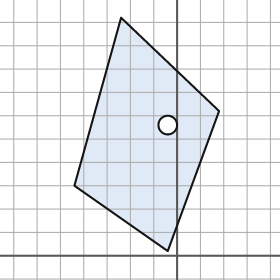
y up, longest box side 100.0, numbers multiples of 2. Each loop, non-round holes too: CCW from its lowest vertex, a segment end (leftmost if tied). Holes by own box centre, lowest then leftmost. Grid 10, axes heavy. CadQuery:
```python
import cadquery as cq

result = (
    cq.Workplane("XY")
    .moveTo(-4.0, 2.0)
    .lineTo(18.0, 62.0)
    .lineTo(-24.0, 102.0)
    .lineTo(-44.0, 30.0)
    .close()
    .moveTo(-4.0, 56.0)
    .circle(4.0)
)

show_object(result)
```